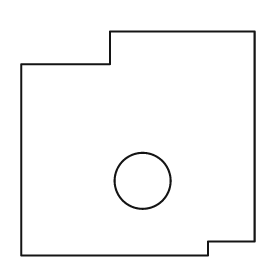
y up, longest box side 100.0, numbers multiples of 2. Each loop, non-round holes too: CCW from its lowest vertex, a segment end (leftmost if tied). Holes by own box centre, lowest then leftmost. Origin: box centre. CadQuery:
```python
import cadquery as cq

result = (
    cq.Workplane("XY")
    .moveTo(-50.0, -48.0)
    .lineTo(30.0, -48.0)
    .lineTo(30.0, -42.0)
    .lineTo(50.0, -42.0)
    .lineTo(50.0, 48.0)
    .lineTo(-12.0, 48.0)
    .lineTo(-12.0, 34.0)
    .lineTo(-50.0, 34.0)
    .close()
    .moveTo(2.0, -16.0)
    .circle(12.0)
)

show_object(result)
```